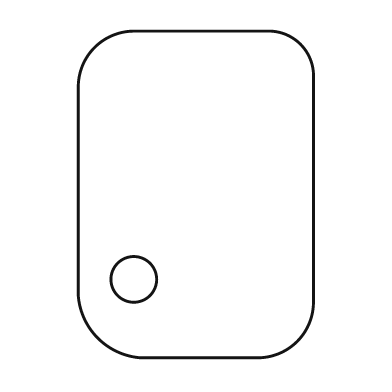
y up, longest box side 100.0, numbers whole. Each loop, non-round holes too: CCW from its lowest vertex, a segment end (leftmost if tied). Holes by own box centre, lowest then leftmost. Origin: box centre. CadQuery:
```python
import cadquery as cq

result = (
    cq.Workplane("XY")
    .moveTo(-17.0, -50.0)
    .lineTo(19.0, -50.0)
    .threePointArc((31.0, -45.0), (36.0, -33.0))
    .lineTo(36.0, 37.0)
    .threePointArc((32.0, 46.0), (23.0, 50.0))
    .lineTo(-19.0, 50.0)
    .threePointArc((-31.0, 45.0), (-36.0, 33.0))
    .lineTo(-36.0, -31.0)
    .threePointArc((-30.0, -44.0), (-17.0, -50.0))
    .close()
    .moveTo(-19.0, -26.0)
    .circle(7.0)
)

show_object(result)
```